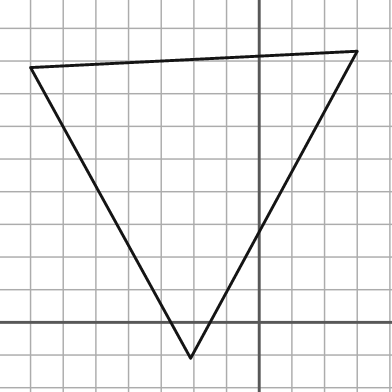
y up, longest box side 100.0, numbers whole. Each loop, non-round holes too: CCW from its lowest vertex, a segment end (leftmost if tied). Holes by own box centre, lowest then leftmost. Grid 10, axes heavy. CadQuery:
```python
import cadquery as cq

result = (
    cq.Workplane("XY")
    .moveTo(-21.0, -11.0)
    .lineTo(30.0, 83.0)
    .lineTo(-70.0, 78.0)
    .close()
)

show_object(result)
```